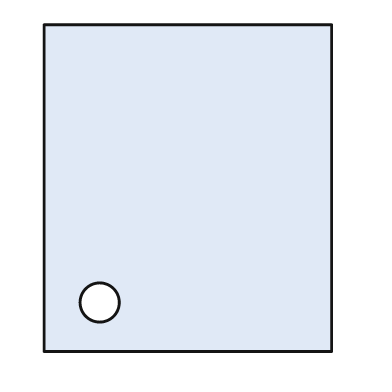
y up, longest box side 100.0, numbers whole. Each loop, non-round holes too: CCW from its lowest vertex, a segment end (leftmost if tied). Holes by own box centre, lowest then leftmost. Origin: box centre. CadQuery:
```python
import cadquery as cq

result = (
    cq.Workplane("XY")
    .moveTo(-44.0, -50.0)
    .lineTo(44.0, -50.0)
    .lineTo(44.0, 50.0)
    .lineTo(-44.0, 50.0)
    .close()
    .moveTo(-27.0, -35.0)
    .circle(6.0)
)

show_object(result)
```